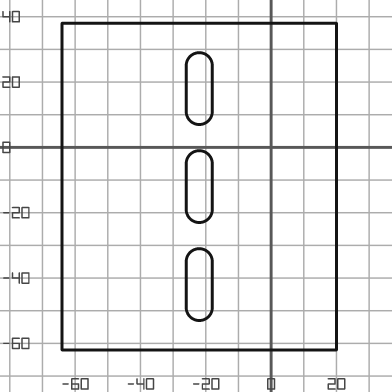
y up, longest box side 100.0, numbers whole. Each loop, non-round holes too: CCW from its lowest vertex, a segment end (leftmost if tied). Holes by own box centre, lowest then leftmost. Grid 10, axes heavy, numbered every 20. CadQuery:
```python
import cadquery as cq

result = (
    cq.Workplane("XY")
    .moveTo(-64.0, -62.0)
    .lineTo(20.0, -62.0)
    .lineTo(20.0, 38.0)
    .lineTo(-64.0, 38.0)
    .close()
    .moveTo(-26.0, -49.0)
    .threePointArc((-22.0, -53.0), (-18.0, -49.0))
    .lineTo(-18.0, -35.0)
    .threePointArc((-22.0, -31.0), (-26.0, -35.0))
    .close()
    .moveTo(-26.0, -19.0)
    .threePointArc((-22.0, -23.0), (-18.0, -19.0))
    .lineTo(-18.0, -5.0)
    .threePointArc((-22.0, -1.0), (-26.0, -5.0))
    .close()
    .moveTo(-26.0, 11.0)
    .threePointArc((-22.0, 7.0), (-18.0, 11.0))
    .lineTo(-18.0, 25.0)
    .threePointArc((-22.0, 29.0), (-26.0, 25.0))
    .close()
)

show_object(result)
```